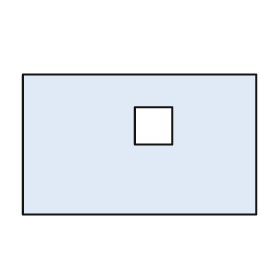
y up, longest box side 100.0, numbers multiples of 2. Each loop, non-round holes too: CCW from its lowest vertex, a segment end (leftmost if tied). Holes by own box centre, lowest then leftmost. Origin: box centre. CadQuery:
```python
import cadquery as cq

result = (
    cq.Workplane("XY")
    .moveTo(-50.0, -30.0)
    .lineTo(50.0, -30.0)
    .lineTo(50.0, 30.0)
    .lineTo(-50.0, 30.0)
    .close()
    .moveTo(-2.0, 0.0)
    .lineTo(14.0, 0.0)
    .lineTo(14.0, 16.0)
    .lineTo(-2.0, 16.0)
    .close()
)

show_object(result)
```